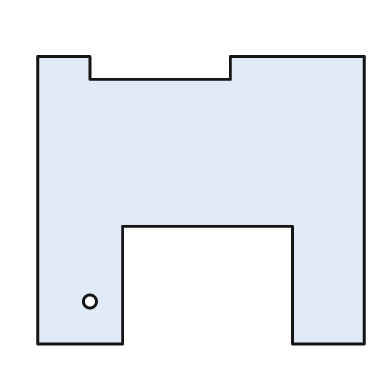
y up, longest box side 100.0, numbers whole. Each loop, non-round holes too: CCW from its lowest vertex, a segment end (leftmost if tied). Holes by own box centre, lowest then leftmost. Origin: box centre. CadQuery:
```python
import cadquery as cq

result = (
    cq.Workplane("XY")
    .moveTo(-50.0, -44.0)
    .lineTo(-24.0, -44.0)
    .lineTo(-24.0, -8.0)
    .lineTo(28.0, -8.0)
    .lineTo(28.0, -44.0)
    .lineTo(50.0, -44.0)
    .lineTo(50.0, 44.0)
    .lineTo(9.0, 44.0)
    .lineTo(9.0, 37.0)
    .lineTo(-34.0, 37.0)
    .lineTo(-34.0, 44.0)
    .lineTo(-50.0, 44.0)
    .close()
    .moveTo(-34.0, -31.0)
    .circle(2.0)
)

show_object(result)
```